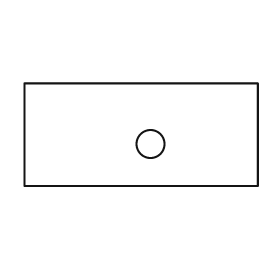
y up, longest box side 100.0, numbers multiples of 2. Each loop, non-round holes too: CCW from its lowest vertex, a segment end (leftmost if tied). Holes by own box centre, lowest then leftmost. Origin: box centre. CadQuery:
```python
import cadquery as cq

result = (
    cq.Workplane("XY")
    .moveTo(-50.0, -22.0)
    .lineTo(50.0, -22.0)
    .lineTo(50.0, 22.0)
    .lineTo(-50.0, 22.0)
    .close()
    .moveTo(4.0, -4.0)
    .circle(6.0)
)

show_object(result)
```